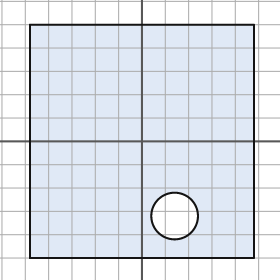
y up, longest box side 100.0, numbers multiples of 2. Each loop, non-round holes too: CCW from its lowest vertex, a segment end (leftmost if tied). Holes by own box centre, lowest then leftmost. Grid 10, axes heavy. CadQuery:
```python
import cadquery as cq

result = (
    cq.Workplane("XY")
    .moveTo(-48.0, -50.0)
    .lineTo(48.0, -50.0)
    .lineTo(48.0, 50.0)
    .lineTo(-48.0, 50.0)
    .close()
    .moveTo(14.0, -32.0)
    .circle(10.0)
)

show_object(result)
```